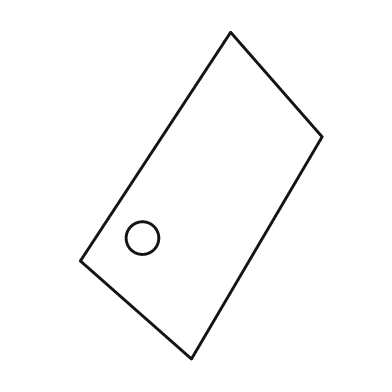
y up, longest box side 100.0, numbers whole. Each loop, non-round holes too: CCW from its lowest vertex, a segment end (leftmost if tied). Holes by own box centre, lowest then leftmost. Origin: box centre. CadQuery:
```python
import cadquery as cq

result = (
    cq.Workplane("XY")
    .moveTo(-3.0, -50.0)
    .lineTo(37.0, 18.0)
    .lineTo(9.0, 50.0)
    .lineTo(-37.0, -20.0)
    .close()
    .moveTo(-18.0, -13.0)
    .circle(5.0)
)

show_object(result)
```